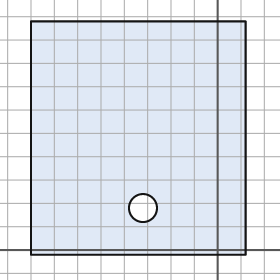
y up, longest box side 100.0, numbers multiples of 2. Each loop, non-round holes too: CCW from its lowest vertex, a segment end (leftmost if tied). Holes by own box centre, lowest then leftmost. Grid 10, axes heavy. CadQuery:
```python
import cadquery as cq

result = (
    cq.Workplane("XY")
    .moveTo(-80.0, -2.0)
    .lineTo(12.0, -2.0)
    .lineTo(12.0, 98.0)
    .lineTo(-80.0, 98.0)
    .close()
    .moveTo(-32.0, 18.0)
    .circle(6.0)
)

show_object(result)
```